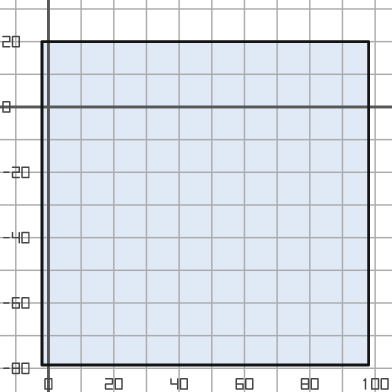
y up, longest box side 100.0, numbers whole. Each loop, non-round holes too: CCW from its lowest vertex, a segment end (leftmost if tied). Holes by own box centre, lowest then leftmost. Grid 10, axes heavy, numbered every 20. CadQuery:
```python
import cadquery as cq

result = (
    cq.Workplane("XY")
    .moveTo(-2.0, -79.0)
    .lineTo(98.0, -79.0)
    .lineTo(98.0, 20.0)
    .lineTo(-2.0, 20.0)
    .close()
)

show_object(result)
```